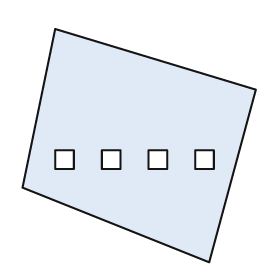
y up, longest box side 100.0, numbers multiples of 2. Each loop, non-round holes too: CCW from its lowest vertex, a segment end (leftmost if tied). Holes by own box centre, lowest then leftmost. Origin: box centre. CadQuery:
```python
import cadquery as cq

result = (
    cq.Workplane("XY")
    .moveTo(30.0, -50.0)
    .lineTo(50.0, 24.0)
    .lineTo(-36.0, 50.0)
    .lineTo(-50.0, -18.0)
    .close()
    .moveTo(-36.0, -10.0)
    .lineTo(-28.0, -10.0)
    .lineTo(-28.0, -2.0)
    .lineTo(-36.0, -2.0)
    .close()
    .moveTo(-16.0, -10.0)
    .lineTo(-8.0, -10.0)
    .lineTo(-8.0, -2.0)
    .lineTo(-16.0, -2.0)
    .close()
    .moveTo(4.0, -10.0)
    .lineTo(12.0, -10.0)
    .lineTo(12.0, -2.0)
    .lineTo(4.0, -2.0)
    .close()
    .moveTo(24.0, -10.0)
    .lineTo(32.0, -10.0)
    .lineTo(32.0, -2.0)
    .lineTo(24.0, -2.0)
    .close()
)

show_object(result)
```